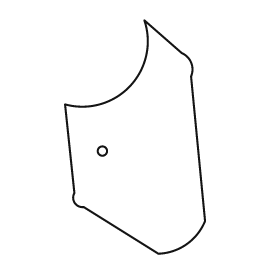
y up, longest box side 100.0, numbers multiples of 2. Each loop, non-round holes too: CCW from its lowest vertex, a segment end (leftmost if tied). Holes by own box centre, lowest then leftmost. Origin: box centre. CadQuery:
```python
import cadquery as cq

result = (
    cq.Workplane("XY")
    .moveTo(10.0, -50.0)
    .threePointArc((22.0, -46.0), (30.0, -36.0))
    .lineTo(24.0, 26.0)
    .threePointArc((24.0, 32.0), (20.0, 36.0))
    .lineTo(4.0, 50.0)
    .threePointArc((-2.0, 22.0), (-30.0, 14.0))
    .lineTo(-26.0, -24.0)
    .threePointArc((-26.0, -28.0), (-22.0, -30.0))
    .close()
    .moveTo(-14.0, -6.0)
    .circle(2.0)
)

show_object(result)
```